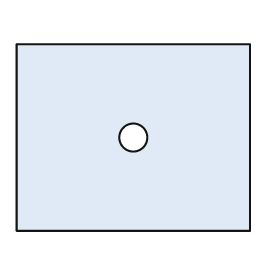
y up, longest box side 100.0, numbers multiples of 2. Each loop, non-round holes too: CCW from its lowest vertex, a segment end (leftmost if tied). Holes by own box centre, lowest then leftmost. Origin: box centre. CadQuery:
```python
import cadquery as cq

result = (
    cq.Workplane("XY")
    .moveTo(-50.0, -40.0)
    .lineTo(50.0, -40.0)
    .lineTo(50.0, 40.0)
    .lineTo(-50.0, 40.0)
    .close()
    .moveTo(0.0, 0.0)
    .circle(6.0)
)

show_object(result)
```